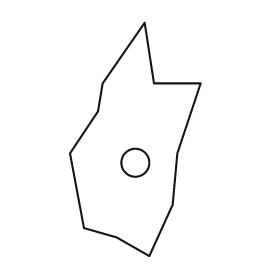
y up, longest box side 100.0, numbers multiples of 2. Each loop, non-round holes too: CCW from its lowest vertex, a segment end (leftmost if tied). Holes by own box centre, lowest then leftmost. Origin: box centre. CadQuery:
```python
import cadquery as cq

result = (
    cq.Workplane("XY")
    .moveTo(6.0, -50.0)
    .lineTo(16.0, -28.0)
    .lineTo(18.0, -6.0)
    .lineTo(28.0, 24.0)
    .lineTo(8.0, 24.0)
    .lineTo(4.0, 50.0)
    .lineTo(-14.0, 24.0)
    .lineTo(-16.0, 12.0)
    .lineTo(-28.0, -6.0)
    .lineTo(-22.0, -38.0)
    .lineTo(-8.0, -42.0)
    .close()
    .moveTo(0.0, -10.0)
    .circle(6.0)
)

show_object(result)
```